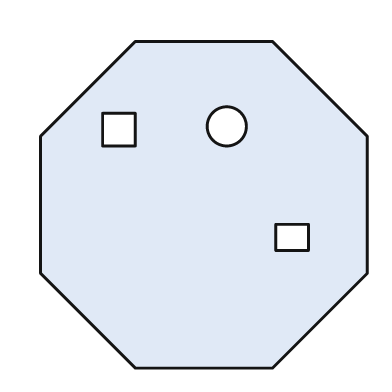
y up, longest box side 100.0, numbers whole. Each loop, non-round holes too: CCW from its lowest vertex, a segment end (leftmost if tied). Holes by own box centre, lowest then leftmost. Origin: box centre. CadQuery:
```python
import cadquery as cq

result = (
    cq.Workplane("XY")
    .moveTo(-21.0, -50.0)
    .lineTo(21.0, -50.0)
    .lineTo(50.0, -21.0)
    .lineTo(50.0, 21.0)
    .lineTo(21.0, 50.0)
    .lineTo(-21.0, 50.0)
    .lineTo(-50.0, 21.0)
    .lineTo(-50.0, -21.0)
    .close()
    .moveTo(22.0, -14.0)
    .lineTo(32.0, -14.0)
    .lineTo(32.0, -6.0)
    .lineTo(22.0, -6.0)
    .close()
    .moveTo(-31.0, 18.0)
    .lineTo(-21.0, 18.0)
    .lineTo(-21.0, 28.0)
    .lineTo(-31.0, 28.0)
    .close()
    .moveTo(7.0, 24.0)
    .circle(6.0)
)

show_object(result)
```